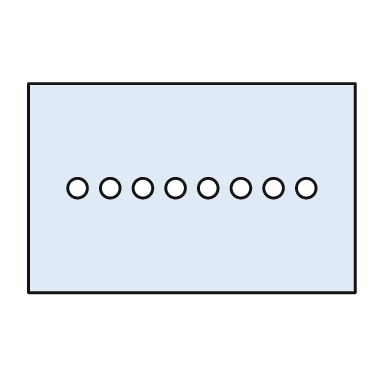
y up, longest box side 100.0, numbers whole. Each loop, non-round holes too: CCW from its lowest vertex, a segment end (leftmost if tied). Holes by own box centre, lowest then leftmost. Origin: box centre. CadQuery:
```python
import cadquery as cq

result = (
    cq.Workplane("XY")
    .moveTo(-50.0, -32.0)
    .lineTo(50.0, -32.0)
    .lineTo(50.0, 32.0)
    .lineTo(-50.0, 32.0)
    .close()
    .moveTo(-35.0, 0.0)
    .circle(3.0)
    .moveTo(-25.0, 0.0)
    .circle(3.0)
    .moveTo(-15.0, 0.0)
    .circle(3.0)
    .moveTo(-5.0, 0.0)
    .circle(3.0)
    .moveTo(5.0, 0.0)
    .circle(3.0)
    .moveTo(15.0, 0.0)
    .circle(3.0)
    .moveTo(25.0, 0.0)
    .circle(3.0)
    .moveTo(35.0, 0.0)
    .circle(3.0)
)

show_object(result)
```